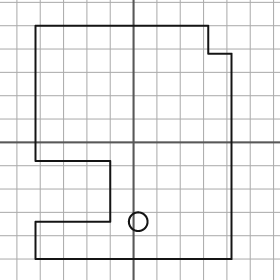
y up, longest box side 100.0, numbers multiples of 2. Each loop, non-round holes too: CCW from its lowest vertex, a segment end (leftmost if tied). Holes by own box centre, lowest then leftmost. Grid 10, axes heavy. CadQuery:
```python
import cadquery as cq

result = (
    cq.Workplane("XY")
    .moveTo(-42.0, -50.0)
    .lineTo(42.0, -50.0)
    .lineTo(42.0, 38.0)
    .lineTo(32.0, 38.0)
    .lineTo(32.0, 50.0)
    .lineTo(-42.0, 50.0)
    .lineTo(-42.0, -8.0)
    .lineTo(-10.0, -8.0)
    .lineTo(-10.0, -34.0)
    .lineTo(-42.0, -34.0)
    .close()
    .moveTo(2.0, -34.0)
    .circle(4.0)
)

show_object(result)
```